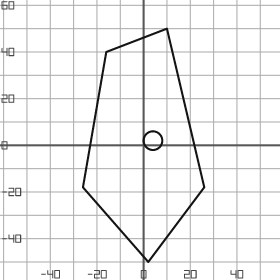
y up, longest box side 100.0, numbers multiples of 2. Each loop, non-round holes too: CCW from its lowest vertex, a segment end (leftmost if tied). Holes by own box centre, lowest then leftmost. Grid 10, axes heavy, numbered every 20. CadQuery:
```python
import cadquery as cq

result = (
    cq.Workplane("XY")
    .moveTo(2.0, -50.0)
    .lineTo(26.0, -18.0)
    .lineTo(10.0, 50.0)
    .lineTo(-16.0, 40.0)
    .lineTo(-26.0, -18.0)
    .close()
    .moveTo(4.0, 2.0)
    .circle(4.0)
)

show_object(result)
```